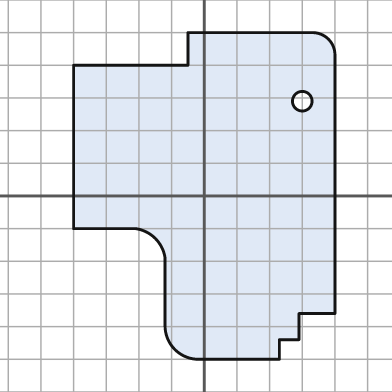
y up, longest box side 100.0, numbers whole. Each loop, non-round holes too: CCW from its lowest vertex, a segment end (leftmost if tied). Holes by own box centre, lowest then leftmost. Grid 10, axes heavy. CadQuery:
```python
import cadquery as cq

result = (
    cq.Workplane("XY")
    .moveTo(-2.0, -50.0)
    .lineTo(23.0, -50.0)
    .lineTo(23.0, -44.0)
    .lineTo(29.0, -44.0)
    .lineTo(29.0, -36.0)
    .lineTo(40.0, -36.0)
    .lineTo(40.0, 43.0)
    .threePointArc((38.0, 48.0), (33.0, 50.0))
    .lineTo(-5.0, 50.0)
    .lineTo(-5.0, 40.0)
    .lineTo(-40.0, 40.0)
    .lineTo(-40.0, -10.0)
    .lineTo(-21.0, -10.0)
    .threePointArc((-15.0, -13.0), (-12.0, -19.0))
    .lineTo(-12.0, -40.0)
    .threePointArc((-9.0, -47.0), (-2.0, -50.0))
    .close()
    .moveTo(30.0, 29.0)
    .circle(3.0)
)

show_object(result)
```